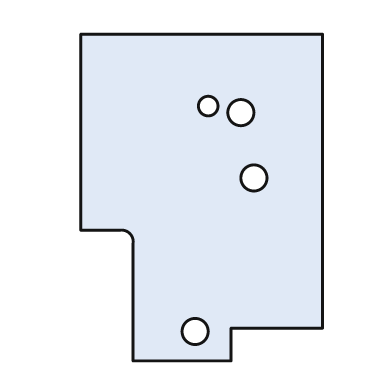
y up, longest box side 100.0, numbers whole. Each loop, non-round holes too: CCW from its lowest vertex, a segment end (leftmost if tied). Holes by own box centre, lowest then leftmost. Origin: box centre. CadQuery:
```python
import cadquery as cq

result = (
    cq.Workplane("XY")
    .moveTo(-21.0, -50.0)
    .lineTo(9.0, -50.0)
    .lineTo(9.0, -40.0)
    .lineTo(37.0, -40.0)
    .lineTo(37.0, 50.0)
    .lineTo(-37.0, 50.0)
    .lineTo(-37.0, -10.0)
    .lineTo(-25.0, -10.0)
    .threePointArc((-22.0, -11.0), (-21.0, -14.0))
    .close()
    .moveTo(-2.0, -41.0)
    .circle(4.0)
    .moveTo(16.0, 6.0)
    .circle(4.0)
    .moveTo(12.0, 26.0)
    .circle(4.0)
    .moveTo(2.0, 28.0)
    .circle(3.0)
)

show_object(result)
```